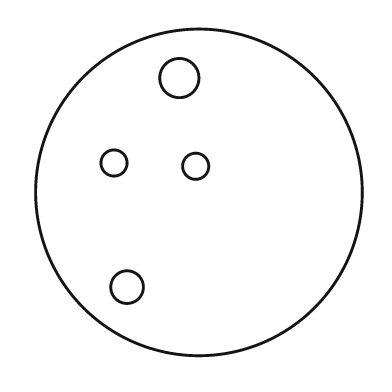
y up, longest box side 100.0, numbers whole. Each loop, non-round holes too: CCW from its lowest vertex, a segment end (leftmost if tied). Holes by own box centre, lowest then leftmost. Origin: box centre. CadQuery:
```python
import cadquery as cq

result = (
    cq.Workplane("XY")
    .moveTo(0.0, 0.0)
    .circle(50.0)
    .moveTo(-22.0, -29.0)
    .circle(5.0)
    .moveTo(-1.0, 8.0)
    .circle(4.0)
    .moveTo(-26.0, 9.0)
    .circle(4.0)
    .moveTo(-6.0, 35.0)
    .circle(6.0)
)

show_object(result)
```